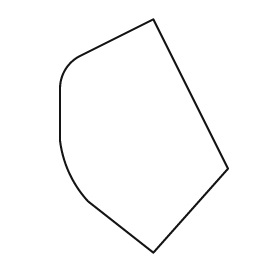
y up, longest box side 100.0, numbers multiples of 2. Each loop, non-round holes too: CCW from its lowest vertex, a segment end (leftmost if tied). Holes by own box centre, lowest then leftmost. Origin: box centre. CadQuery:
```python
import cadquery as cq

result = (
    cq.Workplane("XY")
    .moveTo(4.0, -50.0)
    .lineTo(36.0, -14.0)
    .lineTo(4.0, 50.0)
    .lineTo(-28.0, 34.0)
    .threePointArc((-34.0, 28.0), (-36.0, 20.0))
    .lineTo(-36.0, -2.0)
    .threePointArc((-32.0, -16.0), (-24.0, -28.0))
    .close()
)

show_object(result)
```